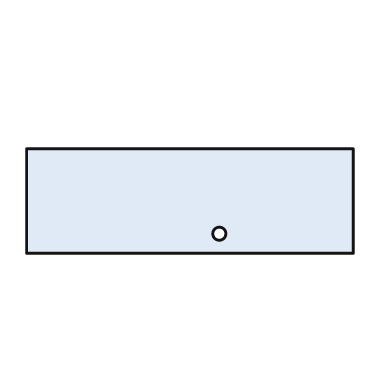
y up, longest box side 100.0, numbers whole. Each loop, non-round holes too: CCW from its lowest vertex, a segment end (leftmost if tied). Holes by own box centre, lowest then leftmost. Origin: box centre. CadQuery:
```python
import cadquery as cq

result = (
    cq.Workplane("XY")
    .moveTo(-50.0, -16.0)
    .lineTo(50.0, -16.0)
    .lineTo(50.0, 16.0)
    .lineTo(-50.0, 16.0)
    .close()
    .moveTo(9.0, -10.0)
    .circle(2.0)
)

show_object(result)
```